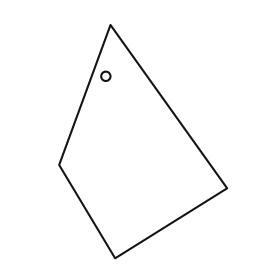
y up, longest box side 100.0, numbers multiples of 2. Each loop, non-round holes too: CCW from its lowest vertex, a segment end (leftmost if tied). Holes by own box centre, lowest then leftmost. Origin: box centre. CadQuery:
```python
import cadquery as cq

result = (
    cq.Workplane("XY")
    .moveTo(-12.0, -50.0)
    .lineTo(36.0, -20.0)
    .lineTo(-14.0, 50.0)
    .lineTo(-36.0, -10.0)
    .close()
    .moveTo(-16.0, 28.0)
    .circle(2.0)
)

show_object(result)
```